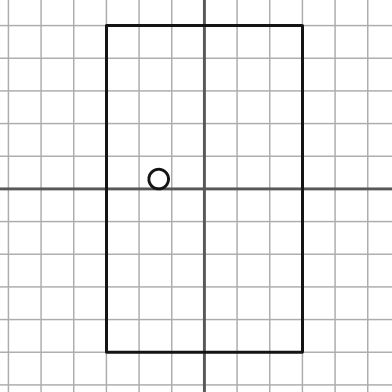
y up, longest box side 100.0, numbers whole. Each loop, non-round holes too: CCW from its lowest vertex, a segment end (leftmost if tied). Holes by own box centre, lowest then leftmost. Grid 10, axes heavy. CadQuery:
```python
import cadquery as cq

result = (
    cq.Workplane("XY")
    .moveTo(-30.0, -50.0)
    .lineTo(30.0, -50.0)
    .lineTo(30.0, 50.0)
    .lineTo(-30.0, 50.0)
    .close()
    .moveTo(-14.0, 3.0)
    .circle(3.0)
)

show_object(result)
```